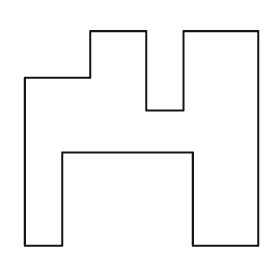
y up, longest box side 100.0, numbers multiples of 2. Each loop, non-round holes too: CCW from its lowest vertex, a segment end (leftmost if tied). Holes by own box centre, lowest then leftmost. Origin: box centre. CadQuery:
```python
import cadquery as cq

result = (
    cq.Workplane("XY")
    .moveTo(-50.0, -46.0)
    .lineTo(-34.0, -46.0)
    .lineTo(-34.0, -6.0)
    .lineTo(22.0, -6.0)
    .lineTo(22.0, -46.0)
    .lineTo(50.0, -46.0)
    .lineTo(50.0, 46.0)
    .lineTo(18.0, 46.0)
    .lineTo(18.0, 12.0)
    .lineTo(2.0, 12.0)
    .lineTo(2.0, 46.0)
    .lineTo(-22.0, 46.0)
    .lineTo(-22.0, 26.0)
    .lineTo(-50.0, 26.0)
    .close()
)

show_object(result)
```